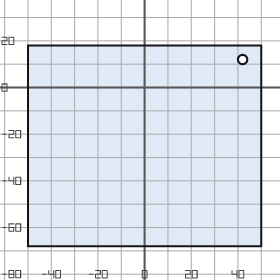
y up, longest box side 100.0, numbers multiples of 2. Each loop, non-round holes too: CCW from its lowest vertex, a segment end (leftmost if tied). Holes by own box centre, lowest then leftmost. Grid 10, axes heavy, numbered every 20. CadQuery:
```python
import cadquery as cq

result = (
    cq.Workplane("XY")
    .moveTo(-50.0, -68.0)
    .lineTo(50.0, -68.0)
    .lineTo(50.0, 18.0)
    .lineTo(-50.0, 18.0)
    .close()
    .moveTo(42.0, 12.0)
    .circle(2.0)
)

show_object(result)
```